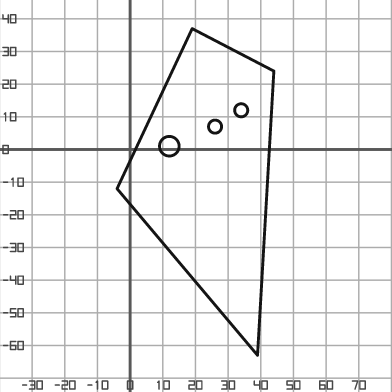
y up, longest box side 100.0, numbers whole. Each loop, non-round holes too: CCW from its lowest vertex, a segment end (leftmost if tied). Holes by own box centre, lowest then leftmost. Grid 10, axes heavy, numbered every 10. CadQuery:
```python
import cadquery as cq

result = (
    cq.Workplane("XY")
    .moveTo(39.0, -63.0)
    .lineTo(44.0, 24.0)
    .lineTo(19.0, 37.0)
    .lineTo(-4.0, -12.0)
    .close()
    .moveTo(12.0, 1.0)
    .circle(3.0)
    .moveTo(26.0, 7.0)
    .circle(2.0)
    .moveTo(34.0, 12.0)
    .circle(2.0)
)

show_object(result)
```